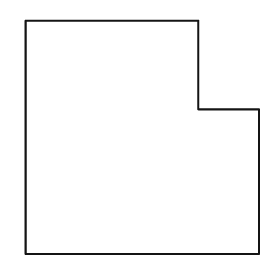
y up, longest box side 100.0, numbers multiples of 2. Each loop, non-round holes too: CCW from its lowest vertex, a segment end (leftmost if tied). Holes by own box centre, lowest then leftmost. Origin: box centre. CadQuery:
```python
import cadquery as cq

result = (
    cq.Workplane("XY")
    .moveTo(-50.0, -50.0)
    .lineTo(50.0, -50.0)
    .lineTo(50.0, 12.0)
    .lineTo(24.0, 12.0)
    .lineTo(24.0, 50.0)
    .lineTo(-50.0, 50.0)
    .close()
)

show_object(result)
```